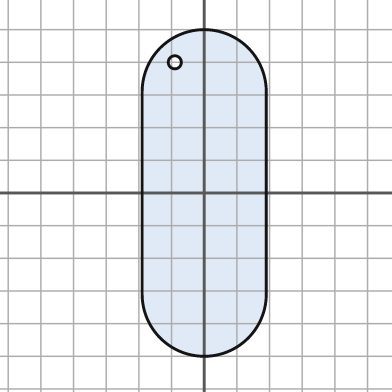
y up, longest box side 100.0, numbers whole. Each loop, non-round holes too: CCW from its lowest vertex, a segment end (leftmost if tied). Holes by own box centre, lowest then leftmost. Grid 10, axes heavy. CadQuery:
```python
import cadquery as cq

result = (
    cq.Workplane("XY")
    .moveTo(-19.0, -31.0)
    .threePointArc((0.0, -50.0), (19.0, -31.0))
    .lineTo(19.0, 31.0)
    .threePointArc((0.0, 50.0), (-19.0, 31.0))
    .close()
    .moveTo(-9.0, 40.0)
    .circle(2.0)
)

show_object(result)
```